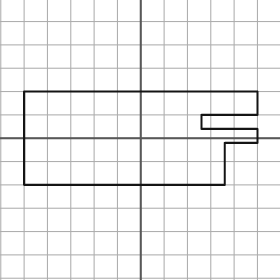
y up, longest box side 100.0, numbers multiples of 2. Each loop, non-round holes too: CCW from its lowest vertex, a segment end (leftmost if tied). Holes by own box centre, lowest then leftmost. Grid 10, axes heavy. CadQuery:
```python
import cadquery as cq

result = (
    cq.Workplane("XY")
    .moveTo(-50.0, -20.0)
    .lineTo(36.0, -20.0)
    .lineTo(36.0, -2.0)
    .lineTo(50.0, -2.0)
    .lineTo(50.0, 4.0)
    .lineTo(26.0, 4.0)
    .lineTo(26.0, 10.0)
    .lineTo(50.0, 10.0)
    .lineTo(50.0, 20.0)
    .lineTo(-50.0, 20.0)
    .close()
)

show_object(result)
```